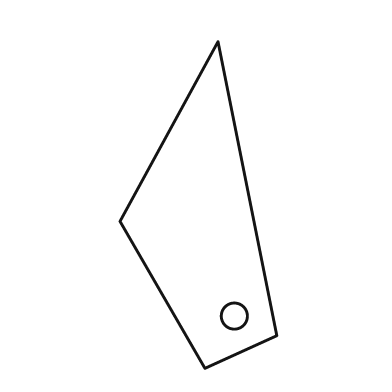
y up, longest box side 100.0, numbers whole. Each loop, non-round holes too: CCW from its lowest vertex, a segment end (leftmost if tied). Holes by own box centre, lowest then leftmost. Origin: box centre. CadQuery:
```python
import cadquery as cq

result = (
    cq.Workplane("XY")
    .moveTo(2.0, -50.0)
    .lineTo(24.0, -40.0)
    .lineTo(6.0, 50.0)
    .lineTo(-24.0, -5.0)
    .close()
    .moveTo(11.0, -34.0)
    .circle(4.0)
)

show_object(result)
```